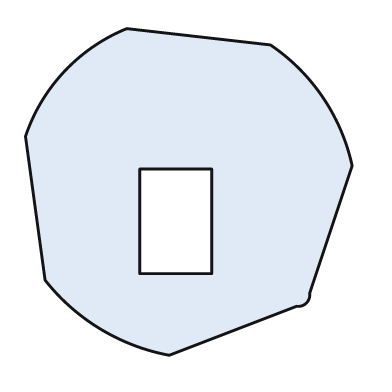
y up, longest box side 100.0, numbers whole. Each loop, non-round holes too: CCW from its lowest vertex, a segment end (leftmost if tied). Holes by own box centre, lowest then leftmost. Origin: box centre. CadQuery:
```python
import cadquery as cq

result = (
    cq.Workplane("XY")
    .moveTo(-6.0, -50.0)
    .lineTo(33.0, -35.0)
    .threePointArc((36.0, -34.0), (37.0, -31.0))
    .lineTo(50.0, 8.0)
    .threePointArc((41.0, 29.0), (25.0, 45.0))
    .lineTo(-19.0, 50.0)
    .threePointArc((-38.0, 37.0), (-50.0, 17.0))
    .lineTo(-44.0, -27.0)
    .threePointArc((-27.0, -42.0), (-6.0, -50.0))
    .close()
    .moveTo(-15.0, -25.0)
    .lineTo(7.0, -25.0)
    .lineTo(7.0, 7.0)
    .lineTo(-15.0, 7.0)
    .close()
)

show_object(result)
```